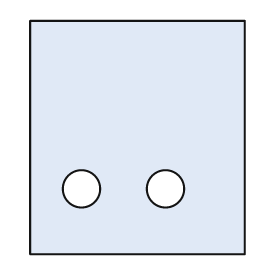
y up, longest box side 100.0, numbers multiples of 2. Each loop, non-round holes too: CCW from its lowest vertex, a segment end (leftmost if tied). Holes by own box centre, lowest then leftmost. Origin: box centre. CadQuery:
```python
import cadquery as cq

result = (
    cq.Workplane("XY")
    .moveTo(-46.0, -50.0)
    .lineTo(46.0, -50.0)
    .lineTo(46.0, 50.0)
    .lineTo(-46.0, 50.0)
    .close()
    .moveTo(-24.0, -22.0)
    .circle(8.0)
    .moveTo(12.0, -22.0)
    .circle(8.0)
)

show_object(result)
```